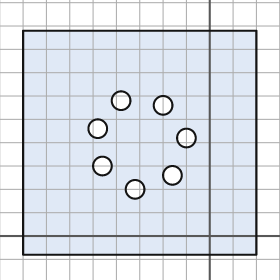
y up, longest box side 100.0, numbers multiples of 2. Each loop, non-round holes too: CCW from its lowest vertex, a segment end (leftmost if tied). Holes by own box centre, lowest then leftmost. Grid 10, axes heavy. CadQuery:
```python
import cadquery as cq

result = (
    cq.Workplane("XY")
    .moveTo(-80.0, -8.0)
    .lineTo(20.0, -8.0)
    .lineTo(20.0, 88.0)
    .lineTo(-80.0, 88.0)
    .close()
    .moveTo(-32.0, 20.0)
    .circle(4.0)
    .moveTo(-16.0, 26.0)
    .circle(4.0)
    .moveTo(-46.0, 30.0)
    .circle(4.0)
    .moveTo(-10.0, 42.0)
    .circle(4.0)
    .moveTo(-48.0, 46.0)
    .circle(4.0)
    .moveTo(-20.0, 56.0)
    .circle(4.0)
    .moveTo(-38.0, 58.0)
    .circle(4.0)
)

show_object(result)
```